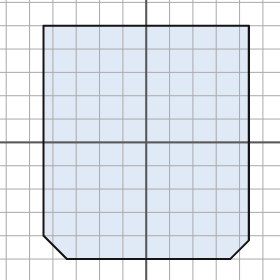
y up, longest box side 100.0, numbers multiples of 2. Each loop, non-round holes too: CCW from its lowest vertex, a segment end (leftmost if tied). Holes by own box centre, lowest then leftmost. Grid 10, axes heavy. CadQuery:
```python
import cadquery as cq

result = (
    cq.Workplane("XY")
    .moveTo(-34.0, -50.0)
    .lineTo(36.0, -50.0)
    .lineTo(44.0, -42.0)
    .lineTo(44.0, 50.0)
    .lineTo(-44.0, 50.0)
    .lineTo(-44.0, -40.0)
    .close()
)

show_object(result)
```